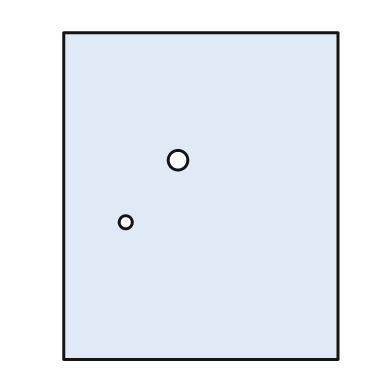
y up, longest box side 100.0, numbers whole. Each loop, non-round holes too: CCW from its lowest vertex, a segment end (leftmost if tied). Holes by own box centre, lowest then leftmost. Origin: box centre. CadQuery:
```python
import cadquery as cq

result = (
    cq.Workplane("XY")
    .moveTo(-42.0, -50.0)
    .lineTo(42.0, -50.0)
    .lineTo(42.0, 50.0)
    .lineTo(-42.0, 50.0)
    .close()
    .moveTo(-23.0, -8.0)
    .circle(2.0)
    .moveTo(-7.0, 11.0)
    .circle(3.0)
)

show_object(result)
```